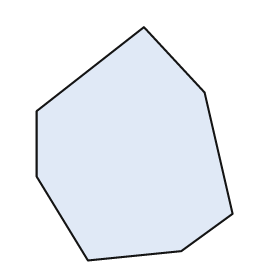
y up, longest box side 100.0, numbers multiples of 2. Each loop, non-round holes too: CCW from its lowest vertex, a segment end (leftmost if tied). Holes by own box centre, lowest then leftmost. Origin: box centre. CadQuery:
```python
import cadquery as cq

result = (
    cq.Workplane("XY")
    .moveTo(-20.0, -50.0)
    .lineTo(20.0, -46.0)
    .lineTo(42.0, -30.0)
    .lineTo(30.0, 22.0)
    .lineTo(4.0, 50.0)
    .lineTo(-42.0, 14.0)
    .lineTo(-42.0, -14.0)
    .close()
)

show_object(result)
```